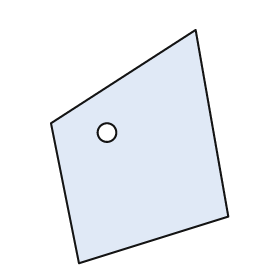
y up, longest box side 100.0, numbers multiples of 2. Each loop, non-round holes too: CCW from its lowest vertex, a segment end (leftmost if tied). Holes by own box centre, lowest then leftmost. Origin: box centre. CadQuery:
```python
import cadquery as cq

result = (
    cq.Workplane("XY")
    .moveTo(-26.0, -50.0)
    .lineTo(38.0, -30.0)
    .lineTo(24.0, 50.0)
    .lineTo(-38.0, 10.0)
    .close()
    .moveTo(-14.0, 6.0)
    .circle(4.0)
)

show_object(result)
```